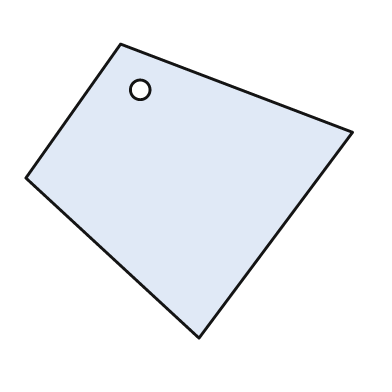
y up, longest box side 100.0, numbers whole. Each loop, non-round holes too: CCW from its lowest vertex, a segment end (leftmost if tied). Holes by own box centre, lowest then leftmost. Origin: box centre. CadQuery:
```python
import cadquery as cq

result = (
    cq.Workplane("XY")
    .moveTo(3.0, -45.0)
    .lineTo(50.0, 18.0)
    .lineTo(-21.0, 45.0)
    .lineTo(-50.0, 4.0)
    .close()
    .moveTo(-15.0, 31.0)
    .circle(3.0)
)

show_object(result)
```